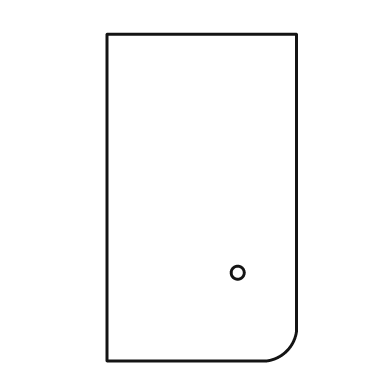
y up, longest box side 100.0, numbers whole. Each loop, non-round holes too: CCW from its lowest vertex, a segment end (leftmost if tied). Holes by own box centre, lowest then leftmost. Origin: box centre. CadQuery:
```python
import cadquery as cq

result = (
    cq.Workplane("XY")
    .moveTo(-29.0, -50.0)
    .lineTo(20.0, -50.0)
    .threePointArc((26.0, -47.0), (29.0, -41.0))
    .lineTo(29.0, 50.0)
    .lineTo(-29.0, 50.0)
    .close()
    .moveTo(11.0, -23.0)
    .circle(2.0)
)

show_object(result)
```